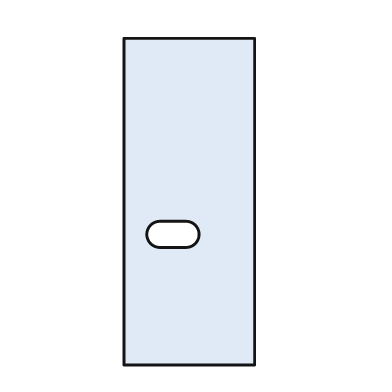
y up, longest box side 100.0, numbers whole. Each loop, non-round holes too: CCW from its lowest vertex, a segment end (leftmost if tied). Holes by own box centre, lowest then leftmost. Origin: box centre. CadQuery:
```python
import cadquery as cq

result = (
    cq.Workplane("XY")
    .moveTo(-20.0, -50.0)
    .lineTo(20.0, -50.0)
    .lineTo(20.0, 50.0)
    .lineTo(-20.0, 50.0)
    .close()
    .moveTo(-9.0, -14.0)
    .lineTo(-1.0, -14.0)
    .threePointArc((3.0, -10.0), (-1.0, -6.0))
    .lineTo(-9.0, -6.0)
    .threePointArc((-13.0, -10.0), (-9.0, -14.0))
    .close()
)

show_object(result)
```